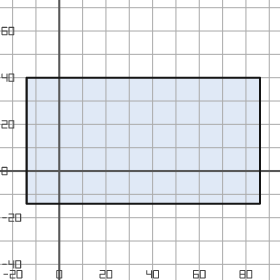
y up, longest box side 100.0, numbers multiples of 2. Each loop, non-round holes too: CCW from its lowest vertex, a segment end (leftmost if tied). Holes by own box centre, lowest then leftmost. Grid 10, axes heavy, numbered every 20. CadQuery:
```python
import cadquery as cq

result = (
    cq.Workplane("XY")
    .moveTo(-14.0, -14.0)
    .lineTo(86.0, -14.0)
    .lineTo(86.0, 40.0)
    .lineTo(-14.0, 40.0)
    .close()
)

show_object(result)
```